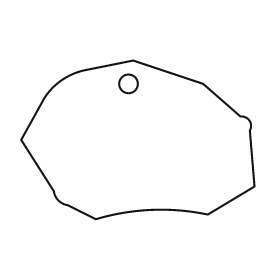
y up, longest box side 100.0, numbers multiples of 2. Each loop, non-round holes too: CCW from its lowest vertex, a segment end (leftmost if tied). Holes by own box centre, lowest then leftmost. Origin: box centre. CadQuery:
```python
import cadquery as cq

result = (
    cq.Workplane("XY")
    .moveTo(-18.0, -34.0)
    .threePointArc((6.0, -30.0), (30.0, -32.0))
    .lineTo(50.0, -20.0)
    .lineTo(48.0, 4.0)
    .threePointArc((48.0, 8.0), (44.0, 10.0))
    .lineTo(28.0, 24.0)
    .lineTo(-2.0, 34.0)
    .lineTo(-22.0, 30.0)
    .threePointArc((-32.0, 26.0), (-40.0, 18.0))
    .lineTo(-50.0, 0.0)
    .lineTo(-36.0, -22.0)
    .threePointArc((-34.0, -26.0), (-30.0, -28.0))
    .close()
    .moveTo(-4.0, 24.0)
    .circle(4.0)
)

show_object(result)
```